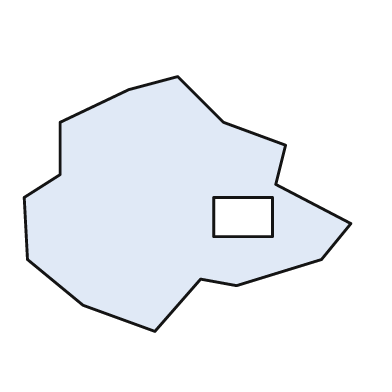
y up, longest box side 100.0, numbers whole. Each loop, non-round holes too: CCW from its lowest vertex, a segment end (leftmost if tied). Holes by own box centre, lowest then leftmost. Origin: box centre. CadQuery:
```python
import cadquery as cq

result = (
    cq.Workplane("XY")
    .moveTo(-10.0, -39.0)
    .lineTo(4.0, -23.0)
    .lineTo(15.0, -25.0)
    .lineTo(41.0, -17.0)
    .lineTo(50.0, -6.0)
    .lineTo(27.0, 6.0)
    .lineTo(30.0, 18.0)
    .lineTo(11.0, 25.0)
    .lineTo(-3.0, 39.0)
    .lineTo(-18.0, 35.0)
    .lineTo(-39.0, 25.0)
    .lineTo(-39.0, 9.0)
    .lineTo(-50.0, 2.0)
    .lineTo(-49.0, -17.0)
    .lineTo(-32.0, -31.0)
    .close()
    .moveTo(8.0, -10.0)
    .lineTo(26.0, -10.0)
    .lineTo(26.0, 2.0)
    .lineTo(8.0, 2.0)
    .close()
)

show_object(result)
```